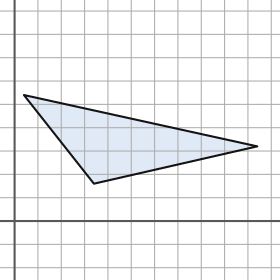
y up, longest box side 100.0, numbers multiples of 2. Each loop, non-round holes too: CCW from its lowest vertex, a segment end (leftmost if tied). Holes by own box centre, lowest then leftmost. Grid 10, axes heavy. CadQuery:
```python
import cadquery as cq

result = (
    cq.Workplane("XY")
    .moveTo(34.0, 16.0)
    .lineTo(104.0, 32.0)
    .lineTo(4.0, 54.0)
    .close()
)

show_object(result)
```